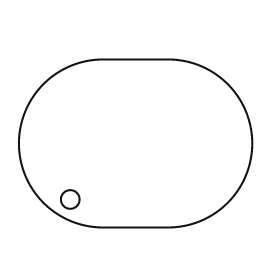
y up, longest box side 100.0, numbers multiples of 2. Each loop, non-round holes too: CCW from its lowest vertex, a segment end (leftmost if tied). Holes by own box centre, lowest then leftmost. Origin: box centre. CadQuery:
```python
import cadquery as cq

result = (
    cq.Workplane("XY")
    .moveTo(-14.0, -36.0)
    .lineTo(14.0, -36.0)
    .threePointArc((50.0, 0.0), (14.0, 36.0))
    .lineTo(-14.0, 36.0)
    .threePointArc((-50.0, 0.0), (-14.0, -36.0))
    .close()
    .moveTo(-28.0, -24.0)
    .circle(4.0)
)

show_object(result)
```